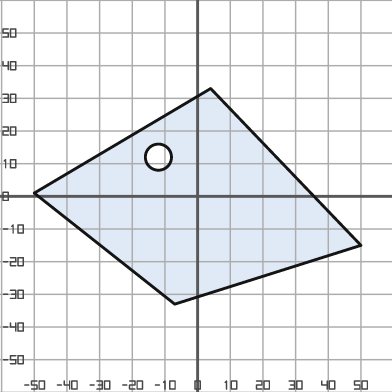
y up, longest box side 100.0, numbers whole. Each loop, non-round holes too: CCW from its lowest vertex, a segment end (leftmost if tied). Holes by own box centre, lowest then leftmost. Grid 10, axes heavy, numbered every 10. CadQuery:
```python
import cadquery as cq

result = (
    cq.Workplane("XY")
    .moveTo(-7.0, -33.0)
    .lineTo(50.0, -15.0)
    .lineTo(4.0, 33.0)
    .lineTo(-50.0, 1.0)
    .close()
    .moveTo(-12.0, 12.0)
    .circle(4.0)
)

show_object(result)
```